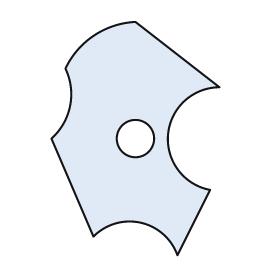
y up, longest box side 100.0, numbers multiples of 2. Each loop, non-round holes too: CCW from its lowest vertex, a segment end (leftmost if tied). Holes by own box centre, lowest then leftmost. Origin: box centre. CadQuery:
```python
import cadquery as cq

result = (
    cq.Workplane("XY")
    .moveTo(18.0, -50.0)
    .lineTo(32.0, -22.0)
    .threePointArc((14.0, 2.0), (36.0, 22.0))
    .lineTo(0.0, 50.0)
    .threePointArc((-18.0, 44.0), (-30.0, 30.0))
    .threePointArc((-28.0, 14.0), (-36.0, 0.0))
    .lineTo(-18.0, -42.0)
    .threePointArc((2.0, -36.0), (18.0, -50.0))
    .close()
    .moveTo(0.0, 0.0)
    .circle(8.0)
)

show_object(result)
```